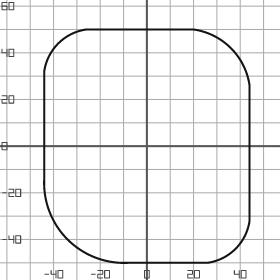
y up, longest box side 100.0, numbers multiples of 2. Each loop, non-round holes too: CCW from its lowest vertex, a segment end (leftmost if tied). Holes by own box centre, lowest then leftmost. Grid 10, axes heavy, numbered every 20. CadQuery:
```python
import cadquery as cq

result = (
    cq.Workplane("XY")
    .moveTo(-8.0, -50.0)
    .lineTo(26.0, -50.0)
    .threePointArc((38.0, -44.0), (44.0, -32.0))
    .lineTo(44.0, 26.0)
    .threePointArc((36.0, 42.0), (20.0, 50.0))
    .lineTo(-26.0, 50.0)
    .threePointArc((-38.0, 44.0), (-44.0, 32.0))
    .lineTo(-44.0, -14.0)
    .threePointArc((-34.0, -40.0), (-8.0, -50.0))
    .close()
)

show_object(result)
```